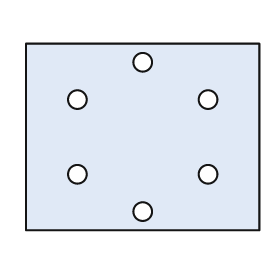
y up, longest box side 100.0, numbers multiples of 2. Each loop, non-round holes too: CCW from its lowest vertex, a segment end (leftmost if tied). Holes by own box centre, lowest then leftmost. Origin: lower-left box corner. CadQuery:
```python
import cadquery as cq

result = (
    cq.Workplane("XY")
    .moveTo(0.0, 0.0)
    .lineTo(100.0, 0.0)
    .lineTo(100.0, 80.0)
    .lineTo(0.0, 80.0)
    .close()
    .moveTo(50.0, 8.0)
    .circle(4.0)
    .moveTo(22.0, 24.0)
    .circle(4.0)
    .moveTo(78.0, 24.0)
    .circle(4.0)
    .moveTo(22.0, 56.0)
    .circle(4.0)
    .moveTo(78.0, 56.0)
    .circle(4.0)
    .moveTo(50.0, 72.0)
    .circle(4.0)
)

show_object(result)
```